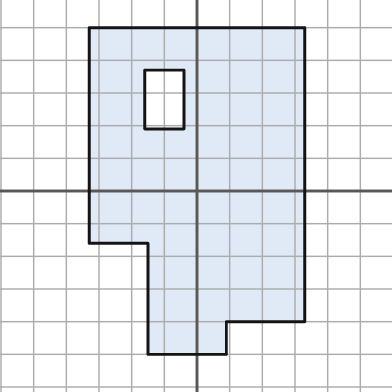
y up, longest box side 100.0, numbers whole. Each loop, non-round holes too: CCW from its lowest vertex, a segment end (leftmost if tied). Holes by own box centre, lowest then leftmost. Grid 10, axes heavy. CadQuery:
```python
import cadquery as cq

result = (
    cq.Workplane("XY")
    .moveTo(-15.0, -50.0)
    .lineTo(9.0, -50.0)
    .lineTo(9.0, -40.0)
    .lineTo(33.0, -40.0)
    .lineTo(33.0, 50.0)
    .lineTo(-33.0, 50.0)
    .lineTo(-33.0, -16.0)
    .lineTo(-15.0, -16.0)
    .close()
    .moveTo(-16.0, 19.0)
    .lineTo(-4.0, 19.0)
    .lineTo(-4.0, 37.0)
    .lineTo(-16.0, 37.0)
    .close()
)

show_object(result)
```